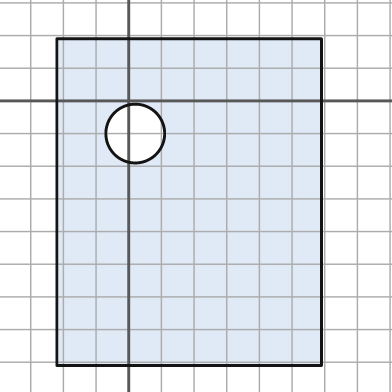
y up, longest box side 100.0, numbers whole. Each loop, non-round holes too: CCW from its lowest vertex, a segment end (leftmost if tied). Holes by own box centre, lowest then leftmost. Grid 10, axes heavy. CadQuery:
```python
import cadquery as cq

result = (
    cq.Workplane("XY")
    .moveTo(-22.0, -81.0)
    .lineTo(59.0, -81.0)
    .lineTo(59.0, 19.0)
    .lineTo(-22.0, 19.0)
    .close()
    .moveTo(2.0, -10.0)
    .circle(9.0)
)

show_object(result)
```